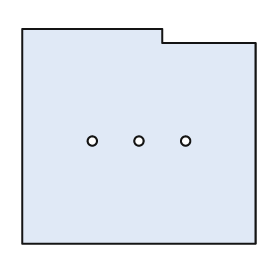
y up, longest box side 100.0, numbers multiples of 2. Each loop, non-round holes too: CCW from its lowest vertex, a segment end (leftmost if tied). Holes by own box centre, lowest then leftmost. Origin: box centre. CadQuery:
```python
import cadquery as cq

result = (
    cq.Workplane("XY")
    .moveTo(-50.0, -46.0)
    .lineTo(50.0, -46.0)
    .lineTo(50.0, 40.0)
    .lineTo(10.0, 40.0)
    .lineTo(10.0, 46.0)
    .lineTo(-50.0, 46.0)
    .close()
    .moveTo(-20.0, -2.0)
    .circle(2.0)
    .moveTo(0.0, -2.0)
    .circle(2.0)
    .moveTo(20.0, -2.0)
    .circle(2.0)
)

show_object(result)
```